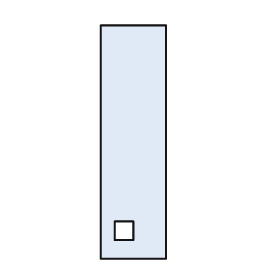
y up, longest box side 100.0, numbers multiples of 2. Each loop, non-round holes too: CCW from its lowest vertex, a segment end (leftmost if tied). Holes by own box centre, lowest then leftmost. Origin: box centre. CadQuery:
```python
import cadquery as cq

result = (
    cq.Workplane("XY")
    .moveTo(-14.0, -50.0)
    .lineTo(14.0, -50.0)
    .lineTo(14.0, 50.0)
    .lineTo(-14.0, 50.0)
    .close()
    .moveTo(-8.0, -42.0)
    .lineTo(0.0, -42.0)
    .lineTo(0.0, -34.0)
    .lineTo(-8.0, -34.0)
    .close()
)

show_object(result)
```